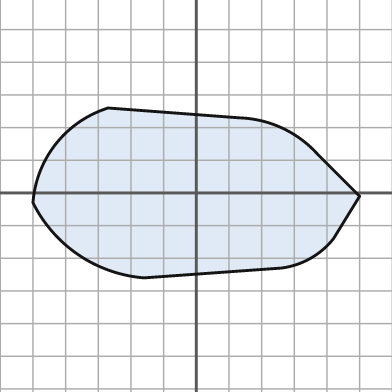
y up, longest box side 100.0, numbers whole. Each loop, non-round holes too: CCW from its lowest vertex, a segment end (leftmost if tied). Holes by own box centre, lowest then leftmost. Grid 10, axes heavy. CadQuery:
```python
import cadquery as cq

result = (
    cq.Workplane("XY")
    .moveTo(-16.0, -26.0)
    .lineTo(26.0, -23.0)
    .threePointArc((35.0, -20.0), (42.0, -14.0))
    .lineTo(50.0, -1.0)
    .lineTo(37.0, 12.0)
    .threePointArc((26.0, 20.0), (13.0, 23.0))
    .lineTo(-27.0, 26.0)
    .threePointArc((-43.0, 15.0), (-50.0, -3.0))
    .threePointArc((-36.0, -19.0), (-16.0, -26.0))
    .close()
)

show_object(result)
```